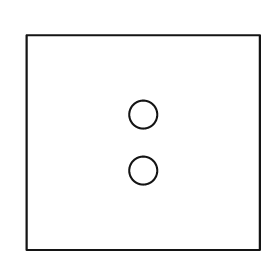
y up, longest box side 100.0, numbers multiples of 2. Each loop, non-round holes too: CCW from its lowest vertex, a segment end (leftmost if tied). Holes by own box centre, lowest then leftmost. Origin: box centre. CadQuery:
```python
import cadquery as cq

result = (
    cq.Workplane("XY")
    .moveTo(-50.0, -46.0)
    .lineTo(50.0, -46.0)
    .lineTo(50.0, 46.0)
    .lineTo(-50.0, 46.0)
    .close()
    .moveTo(0.0, -12.0)
    .circle(6.0)
    .moveTo(0.0, 12.0)
    .circle(6.0)
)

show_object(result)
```